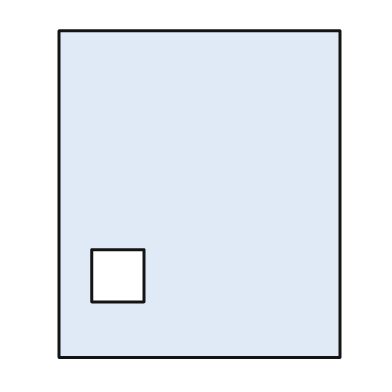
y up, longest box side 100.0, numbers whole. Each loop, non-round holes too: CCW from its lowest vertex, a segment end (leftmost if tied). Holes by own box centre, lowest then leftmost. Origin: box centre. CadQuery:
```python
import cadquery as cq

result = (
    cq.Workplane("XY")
    .moveTo(-43.0, -50.0)
    .lineTo(43.0, -50.0)
    .lineTo(43.0, 50.0)
    .lineTo(-43.0, 50.0)
    .close()
    .moveTo(-33.0, -33.0)
    .lineTo(-17.0, -33.0)
    .lineTo(-17.0, -17.0)
    .lineTo(-33.0, -17.0)
    .close()
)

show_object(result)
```